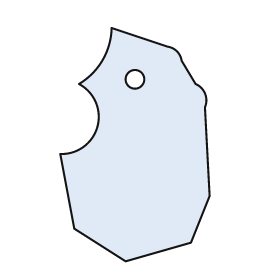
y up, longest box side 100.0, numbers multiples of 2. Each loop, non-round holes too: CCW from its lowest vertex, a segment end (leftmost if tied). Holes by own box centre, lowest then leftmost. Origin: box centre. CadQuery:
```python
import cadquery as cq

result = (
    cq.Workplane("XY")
    .moveTo(-4.0, -50.0)
    .lineTo(24.0, -42.0)
    .lineTo(32.0, -22.0)
    .lineTo(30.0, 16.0)
    .threePointArc((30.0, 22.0), (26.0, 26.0))
    .lineTo(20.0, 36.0)
    .threePointArc((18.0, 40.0), (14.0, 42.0))
    .lineTo(-10.0, 50.0)
    .threePointArc((-14.0, 36.0), (-24.0, 26.0))
    .threePointArc((-16.0, 8.0), (-32.0, -4.0))
    .lineTo(-26.0, -36.0)
    .close()
    .moveTo(0.0, 28.0)
    .circle(4.0)
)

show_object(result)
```